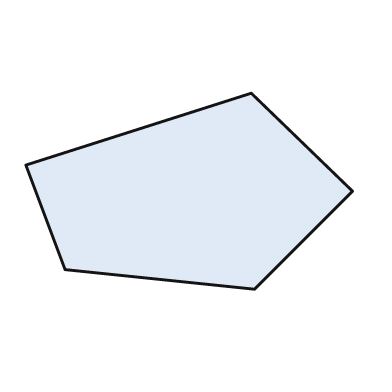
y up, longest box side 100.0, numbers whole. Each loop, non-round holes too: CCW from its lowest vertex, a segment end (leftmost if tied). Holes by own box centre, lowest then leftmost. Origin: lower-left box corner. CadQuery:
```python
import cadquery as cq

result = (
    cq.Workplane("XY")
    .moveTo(70.0, 0.0)
    .lineTo(100.0, 30.0)
    .lineTo(69.0, 60.0)
    .lineTo(0.0, 38.0)
    .lineTo(12.0, 6.0)
    .close()
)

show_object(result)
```